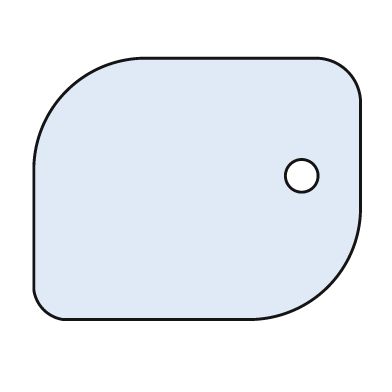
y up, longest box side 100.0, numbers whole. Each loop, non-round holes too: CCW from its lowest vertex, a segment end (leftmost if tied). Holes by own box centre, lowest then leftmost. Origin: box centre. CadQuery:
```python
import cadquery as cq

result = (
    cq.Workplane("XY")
    .moveTo(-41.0, -40.0)
    .lineTo(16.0, -40.0)
    .threePointArc((40.0, -30.0), (50.0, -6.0))
    .lineTo(50.0, 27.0)
    .threePointArc((46.0, 36.0), (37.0, 40.0))
    .lineTo(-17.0, 40.0)
    .threePointArc((-40.0, 30.0), (-50.0, 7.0))
    .lineTo(-50.0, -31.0)
    .threePointArc((-47.0, -37.0), (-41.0, -40.0))
    .close()
    .moveTo(32.0, 4.0)
    .circle(5.0)
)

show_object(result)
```